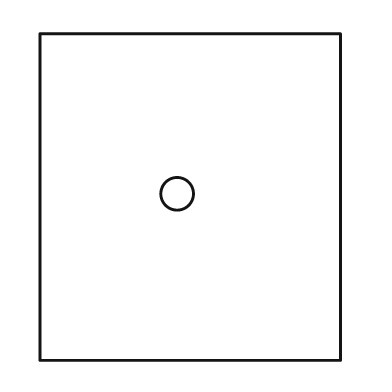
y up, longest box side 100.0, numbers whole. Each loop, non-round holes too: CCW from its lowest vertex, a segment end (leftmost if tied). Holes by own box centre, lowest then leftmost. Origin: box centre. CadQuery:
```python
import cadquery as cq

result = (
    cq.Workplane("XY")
    .moveTo(-46.0, -50.0)
    .lineTo(46.0, -50.0)
    .lineTo(46.0, 50.0)
    .lineTo(-46.0, 50.0)
    .close()
    .moveTo(-4.0, 1.0)
    .circle(5.0)
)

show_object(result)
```